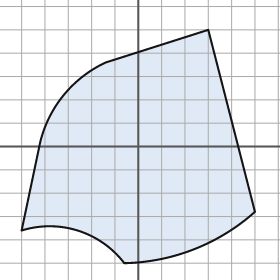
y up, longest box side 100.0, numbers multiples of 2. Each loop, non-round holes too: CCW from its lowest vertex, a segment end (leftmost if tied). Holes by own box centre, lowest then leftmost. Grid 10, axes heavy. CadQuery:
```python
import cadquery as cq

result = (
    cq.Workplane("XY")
    .moveTo(-6.0, -50.0)
    .threePointArc((24.0, -44.0), (50.0, -28.0))
    .lineTo(30.0, 50.0)
    .lineTo(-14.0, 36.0)
    .threePointArc((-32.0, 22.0), (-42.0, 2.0))
    .lineTo(-50.0, -36.0)
    .threePointArc((-26.0, -36.0), (-6.0, -50.0))
    .close()
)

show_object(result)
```